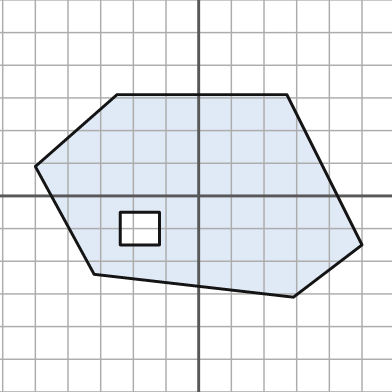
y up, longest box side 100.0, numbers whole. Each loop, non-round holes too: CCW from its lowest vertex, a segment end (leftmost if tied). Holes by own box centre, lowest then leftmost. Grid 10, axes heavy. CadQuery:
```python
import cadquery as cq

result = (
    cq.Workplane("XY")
    .moveTo(29.0, -31.0)
    .lineTo(50.0, -15.0)
    .lineTo(27.0, 31.0)
    .lineTo(-25.0, 31.0)
    .lineTo(-50.0, 9.0)
    .lineTo(-32.0, -24.0)
    .close()
    .moveTo(-24.0, -15.0)
    .lineTo(-12.0, -15.0)
    .lineTo(-12.0, -5.0)
    .lineTo(-24.0, -5.0)
    .close()
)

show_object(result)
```